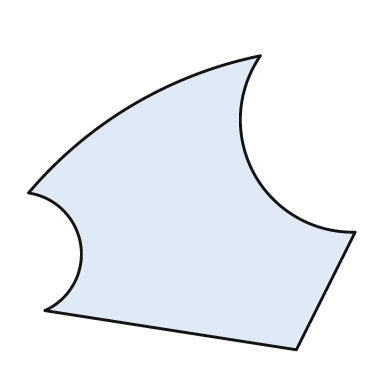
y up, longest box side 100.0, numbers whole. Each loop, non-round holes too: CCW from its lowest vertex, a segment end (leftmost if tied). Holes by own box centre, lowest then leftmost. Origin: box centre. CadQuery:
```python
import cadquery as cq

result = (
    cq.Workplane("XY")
    .moveTo(32.0, -45.0)
    .lineTo(50.0, -9.0)
    .threePointArc((19.0, 9.0), (21.0, 45.0))
    .threePointArc((-18.0, 30.0), (-50.0, 3.0))
    .threePointArc((-34.0, -13.0), (-45.0, -33.0))
    .close()
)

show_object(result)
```